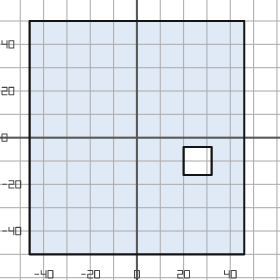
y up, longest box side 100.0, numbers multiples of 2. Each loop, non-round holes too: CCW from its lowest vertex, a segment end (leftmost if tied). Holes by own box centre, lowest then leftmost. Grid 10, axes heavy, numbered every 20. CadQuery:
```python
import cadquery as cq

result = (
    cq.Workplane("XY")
    .moveTo(-46.0, -50.0)
    .lineTo(46.0, -50.0)
    .lineTo(46.0, 50.0)
    .lineTo(-46.0, 50.0)
    .close()
    .moveTo(20.0, -16.0)
    .lineTo(32.0, -16.0)
    .lineTo(32.0, -4.0)
    .lineTo(20.0, -4.0)
    .close()
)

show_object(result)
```